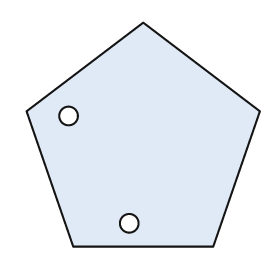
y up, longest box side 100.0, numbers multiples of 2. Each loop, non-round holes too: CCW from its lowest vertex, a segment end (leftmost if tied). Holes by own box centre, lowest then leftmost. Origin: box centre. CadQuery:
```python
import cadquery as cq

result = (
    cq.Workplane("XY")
    .moveTo(-30.0, -48.0)
    .lineTo(30.0, -48.0)
    .lineTo(50.0, 10.0)
    .lineTo(0.0, 48.0)
    .lineTo(-50.0, 10.0)
    .close()
    .moveTo(-6.0, -38.0)
    .circle(4.0)
    .moveTo(-32.0, 8.0)
    .circle(4.0)
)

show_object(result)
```